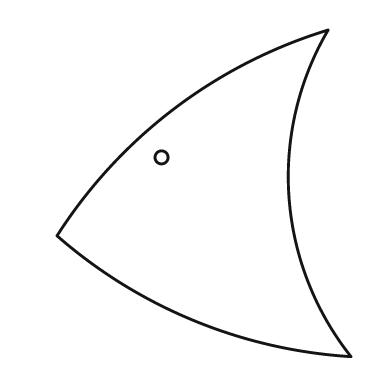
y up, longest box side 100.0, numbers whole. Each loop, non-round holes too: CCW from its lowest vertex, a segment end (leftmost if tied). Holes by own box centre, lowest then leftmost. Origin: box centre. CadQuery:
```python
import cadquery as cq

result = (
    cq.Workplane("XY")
    .moveTo(45.0, -50.0)
    .threePointArc((26.0, -1.0), (38.0, 50.0))
    .threePointArc((-9.0, 26.0), (-45.0, -13.0))
    .threePointArc((-3.0, -39.0), (45.0, -50.0))
    .close()
    .moveTo(-13.0, 11.0)
    .circle(2.0)
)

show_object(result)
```